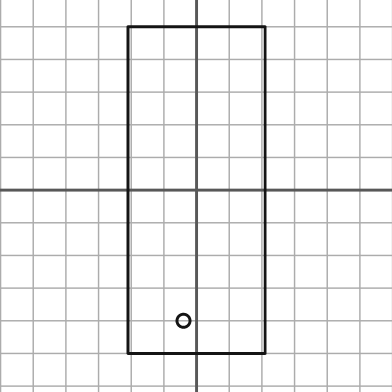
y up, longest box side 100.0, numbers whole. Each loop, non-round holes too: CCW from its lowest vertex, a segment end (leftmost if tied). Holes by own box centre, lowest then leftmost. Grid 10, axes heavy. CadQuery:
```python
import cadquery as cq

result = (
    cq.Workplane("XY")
    .moveTo(-21.0, -50.0)
    .lineTo(21.0, -50.0)
    .lineTo(21.0, 50.0)
    .lineTo(-21.0, 50.0)
    .close()
    .moveTo(-4.0, -40.0)
    .circle(2.0)
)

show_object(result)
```